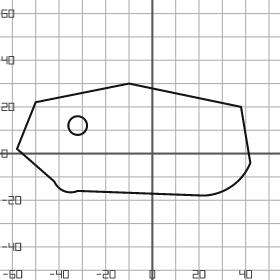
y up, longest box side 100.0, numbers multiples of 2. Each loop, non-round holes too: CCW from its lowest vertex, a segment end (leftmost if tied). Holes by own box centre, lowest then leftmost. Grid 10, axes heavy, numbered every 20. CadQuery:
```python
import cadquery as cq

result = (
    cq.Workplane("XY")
    .moveTo(22.0, -18.0)
    .threePointArc((34.0, -14.0), (42.0, -4.0))
    .lineTo(38.0, 20.0)
    .lineTo(-10.0, 30.0)
    .lineTo(-50.0, 22.0)
    .lineTo(-58.0, 2.0)
    .lineTo(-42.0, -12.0)
    .threePointArc((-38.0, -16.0), (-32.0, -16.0))
    .close()
    .moveTo(-32.0, 12.0)
    .circle(4.0)
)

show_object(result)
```